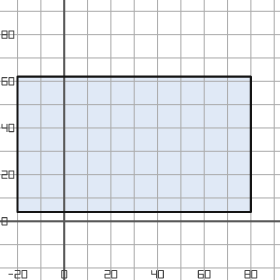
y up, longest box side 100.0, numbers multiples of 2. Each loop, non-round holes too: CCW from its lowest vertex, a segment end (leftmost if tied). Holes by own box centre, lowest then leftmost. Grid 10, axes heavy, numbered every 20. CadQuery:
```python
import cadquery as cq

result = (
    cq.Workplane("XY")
    .moveTo(-20.0, 4.0)
    .lineTo(80.0, 4.0)
    .lineTo(80.0, 62.0)
    .lineTo(-20.0, 62.0)
    .close()
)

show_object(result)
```